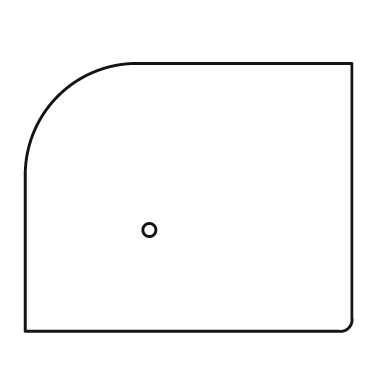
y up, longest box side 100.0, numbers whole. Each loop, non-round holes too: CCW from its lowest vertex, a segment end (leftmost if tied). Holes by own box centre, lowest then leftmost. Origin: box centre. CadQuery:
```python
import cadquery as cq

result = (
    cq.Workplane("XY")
    .moveTo(-50.0, -41.0)
    .lineTo(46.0, -41.0)
    .threePointArc((49.0, -40.0), (50.0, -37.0))
    .lineTo(50.0, 41.0)
    .lineTo(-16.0, 41.0)
    .threePointArc((-40.0, 31.0), (-50.0, 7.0))
    .close()
    .moveTo(-12.0, -10.0)
    .circle(2.0)
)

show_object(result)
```